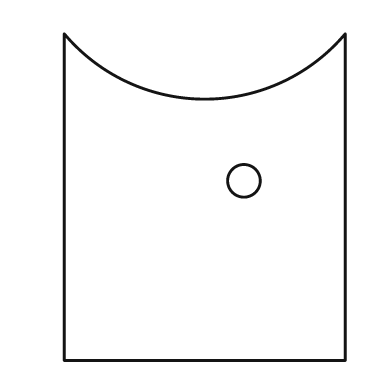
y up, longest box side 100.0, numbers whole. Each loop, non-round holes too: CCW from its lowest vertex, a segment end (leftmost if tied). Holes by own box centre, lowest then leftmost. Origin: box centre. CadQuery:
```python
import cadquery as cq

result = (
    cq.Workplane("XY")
    .moveTo(-43.0, -50.0)
    .lineTo(43.0, -50.0)
    .lineTo(43.0, 50.0)
    .threePointArc((0.0, 30.0), (-43.0, 50.0))
    .close()
    .moveTo(12.0, 5.0)
    .circle(5.0)
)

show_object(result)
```